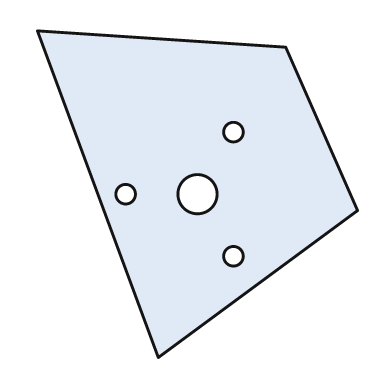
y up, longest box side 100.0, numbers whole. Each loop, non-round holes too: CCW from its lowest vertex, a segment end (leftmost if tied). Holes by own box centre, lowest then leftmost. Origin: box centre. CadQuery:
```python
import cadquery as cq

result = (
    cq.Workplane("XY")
    .moveTo(-12.0, -50.0)
    .lineTo(49.0, -5.0)
    .lineTo(27.0, 45.0)
    .lineTo(-49.0, 50.0)
    .close()
    .moveTo(11.0, -19.0)
    .circle(3.0)
    .moveTo(-22.0, 0.0)
    .circle(3.0)
    .moveTo(0.0, 0.0)
    .circle(6.0)
    .moveTo(11.0, 19.0)
    .circle(3.0)
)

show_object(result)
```